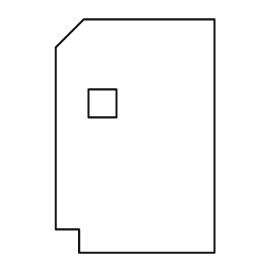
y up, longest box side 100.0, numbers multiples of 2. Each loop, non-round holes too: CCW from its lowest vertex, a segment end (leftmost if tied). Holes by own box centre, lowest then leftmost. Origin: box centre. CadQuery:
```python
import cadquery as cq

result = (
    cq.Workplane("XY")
    .moveTo(-24.0, -50.0)
    .lineTo(34.0, -50.0)
    .lineTo(34.0, 50.0)
    .lineTo(-22.0, 50.0)
    .lineTo(-34.0, 38.0)
    .lineTo(-34.0, -40.0)
    .lineTo(-24.0, -40.0)
    .close()
    .moveTo(-20.0, 8.0)
    .lineTo(-8.0, 8.0)
    .lineTo(-8.0, 20.0)
    .lineTo(-20.0, 20.0)
    .close()
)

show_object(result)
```